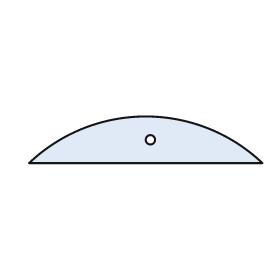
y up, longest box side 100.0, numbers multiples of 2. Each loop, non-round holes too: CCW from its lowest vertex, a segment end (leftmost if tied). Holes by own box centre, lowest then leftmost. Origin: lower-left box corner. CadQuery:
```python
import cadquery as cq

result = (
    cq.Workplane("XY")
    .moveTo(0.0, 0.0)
    .lineTo(100.0, 0.0)
    .threePointArc((50.0, 20.0), (0.0, 0.0))
    .close()
    .moveTo(52.0, 10.0)
    .circle(2.0)
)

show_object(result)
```